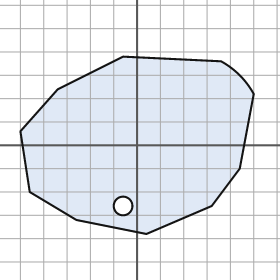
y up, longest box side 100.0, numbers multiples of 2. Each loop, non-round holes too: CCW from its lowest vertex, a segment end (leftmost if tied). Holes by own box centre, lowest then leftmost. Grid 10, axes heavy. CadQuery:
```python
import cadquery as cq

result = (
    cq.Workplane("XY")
    .moveTo(4.0, -38.0)
    .lineTo(32.0, -26.0)
    .lineTo(44.0, -10.0)
    .lineTo(50.0, 22.0)
    .threePointArc((44.0, 30.0), (36.0, 36.0))
    .lineTo(-6.0, 38.0)
    .lineTo(-34.0, 24.0)
    .lineTo(-50.0, 6.0)
    .lineTo(-46.0, -20.0)
    .lineTo(-26.0, -32.0)
    .close()
    .moveTo(-6.0, -26.0)
    .circle(4.0)
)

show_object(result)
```